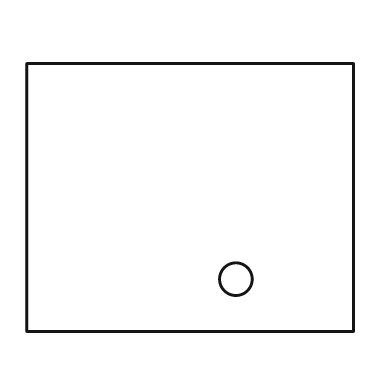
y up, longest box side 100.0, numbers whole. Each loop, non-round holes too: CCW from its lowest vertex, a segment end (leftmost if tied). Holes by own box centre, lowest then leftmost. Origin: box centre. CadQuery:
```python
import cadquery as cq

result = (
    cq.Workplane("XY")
    .moveTo(-50.0, -41.0)
    .lineTo(50.0, -41.0)
    .lineTo(50.0, 41.0)
    .lineTo(-50.0, 41.0)
    .close()
    .moveTo(14.0, -25.0)
    .circle(5.0)
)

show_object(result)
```